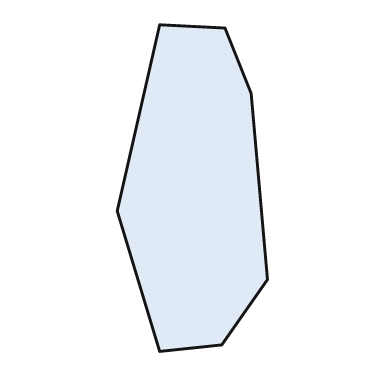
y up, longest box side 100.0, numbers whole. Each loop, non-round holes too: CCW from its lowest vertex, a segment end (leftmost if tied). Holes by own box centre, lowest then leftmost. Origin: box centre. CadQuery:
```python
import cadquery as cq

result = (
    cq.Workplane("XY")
    .moveTo(-10.0, -50.0)
    .lineTo(9.0, -48.0)
    .lineTo(23.0, -28.0)
    .lineTo(18.0, 29.0)
    .lineTo(10.0, 49.0)
    .lineTo(-10.0, 50.0)
    .lineTo(-23.0, -7.0)
    .close()
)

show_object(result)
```